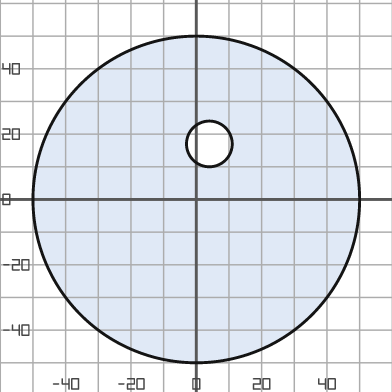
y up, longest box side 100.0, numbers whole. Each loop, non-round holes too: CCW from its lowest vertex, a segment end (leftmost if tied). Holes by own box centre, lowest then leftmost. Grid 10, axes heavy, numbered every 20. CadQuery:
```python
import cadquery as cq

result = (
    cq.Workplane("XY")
    .moveTo(0.0, 0.0)
    .circle(50.0)
    .moveTo(4.0, 17.0)
    .circle(7.0)
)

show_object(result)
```